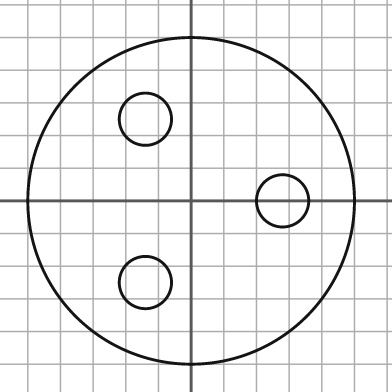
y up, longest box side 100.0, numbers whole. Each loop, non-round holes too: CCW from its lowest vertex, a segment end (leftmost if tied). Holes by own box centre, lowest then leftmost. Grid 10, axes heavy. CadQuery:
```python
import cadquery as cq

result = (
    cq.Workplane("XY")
    .moveTo(0.0, 0.0)
    .circle(50.0)
    .moveTo(-14.0, -25.0)
    .circle(8.0)
    .moveTo(28.0, 0.0)
    .circle(8.0)
    .moveTo(-14.0, 25.0)
    .circle(8.0)
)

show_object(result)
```